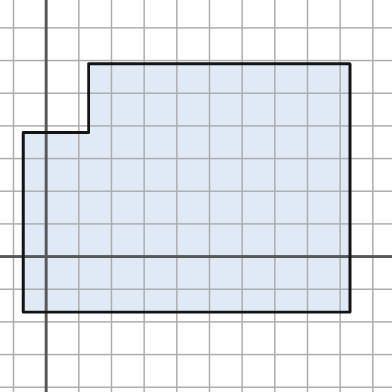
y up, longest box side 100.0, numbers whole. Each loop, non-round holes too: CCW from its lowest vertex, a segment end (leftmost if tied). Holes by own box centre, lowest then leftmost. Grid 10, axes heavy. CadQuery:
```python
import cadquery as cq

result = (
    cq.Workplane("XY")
    .moveTo(-7.0, -17.0)
    .lineTo(93.0, -17.0)
    .lineTo(93.0, 59.0)
    .lineTo(13.0, 59.0)
    .lineTo(13.0, 38.0)
    .lineTo(-7.0, 38.0)
    .close()
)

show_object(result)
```